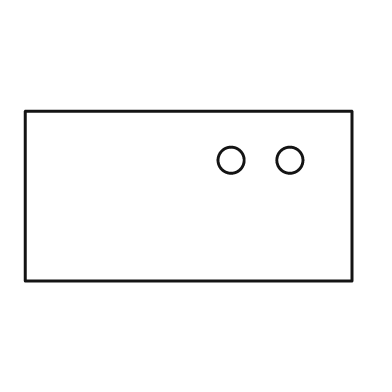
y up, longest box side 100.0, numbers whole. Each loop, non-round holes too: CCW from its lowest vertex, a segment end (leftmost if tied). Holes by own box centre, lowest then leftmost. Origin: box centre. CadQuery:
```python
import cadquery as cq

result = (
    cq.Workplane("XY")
    .moveTo(-50.0, -26.0)
    .lineTo(50.0, -26.0)
    .lineTo(50.0, 26.0)
    .lineTo(-50.0, 26.0)
    .close()
    .moveTo(13.0, 11.0)
    .circle(4.0)
    .moveTo(31.0, 11.0)
    .circle(4.0)
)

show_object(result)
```